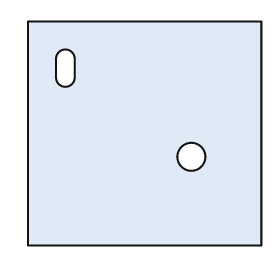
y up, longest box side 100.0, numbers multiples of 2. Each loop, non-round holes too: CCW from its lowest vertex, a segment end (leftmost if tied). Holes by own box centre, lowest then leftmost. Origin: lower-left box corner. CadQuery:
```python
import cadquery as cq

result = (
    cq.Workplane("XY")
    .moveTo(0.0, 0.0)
    .lineTo(100.0, 0.0)
    .lineTo(100.0, 96.0)
    .lineTo(0.0, 96.0)
    .close()
    .moveTo(70.0, 38.0)
    .circle(6.0)
    .moveTo(12.0, 72.0)
    .threePointArc((16.0, 68.0), (20.0, 72.0))
    .lineTo(20.0, 80.0)
    .threePointArc((16.0, 84.0), (12.0, 80.0))
    .close()
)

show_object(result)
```